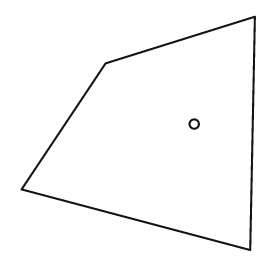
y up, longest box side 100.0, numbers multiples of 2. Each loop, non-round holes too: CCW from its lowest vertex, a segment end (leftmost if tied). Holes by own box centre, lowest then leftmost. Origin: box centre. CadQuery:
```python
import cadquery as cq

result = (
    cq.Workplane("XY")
    .moveTo(48.0, -50.0)
    .lineTo(50.0, 50.0)
    .lineTo(-14.0, 30.0)
    .lineTo(-50.0, -24.0)
    .close()
    .moveTo(24.0, 4.0)
    .circle(2.0)
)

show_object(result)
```